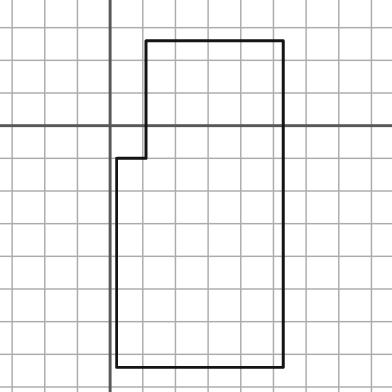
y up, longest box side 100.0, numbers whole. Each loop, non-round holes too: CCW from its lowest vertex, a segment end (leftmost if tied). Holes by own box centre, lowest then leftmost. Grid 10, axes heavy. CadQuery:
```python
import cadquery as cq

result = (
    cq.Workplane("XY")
    .moveTo(2.0, -74.0)
    .lineTo(53.0, -74.0)
    .lineTo(53.0, 26.0)
    .lineTo(11.0, 26.0)
    .lineTo(11.0, -10.0)
    .lineTo(2.0, -10.0)
    .close()
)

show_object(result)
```